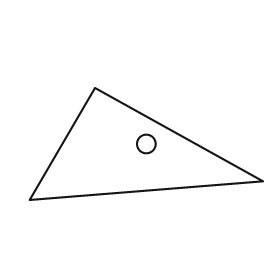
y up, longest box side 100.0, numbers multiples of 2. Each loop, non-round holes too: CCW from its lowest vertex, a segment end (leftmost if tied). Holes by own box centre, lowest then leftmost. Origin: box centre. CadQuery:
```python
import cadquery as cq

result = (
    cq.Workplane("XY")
    .moveTo(-50.0, -24.0)
    .lineTo(50.0, -16.0)
    .lineTo(-22.0, 24.0)
    .close()
    .moveTo(0.0, 0.0)
    .circle(4.0)
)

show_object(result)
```